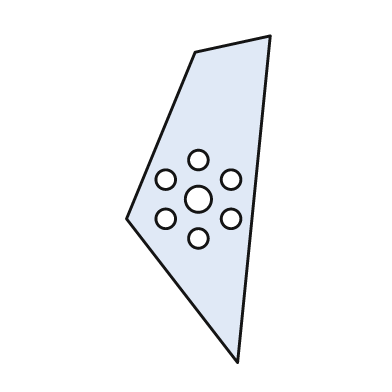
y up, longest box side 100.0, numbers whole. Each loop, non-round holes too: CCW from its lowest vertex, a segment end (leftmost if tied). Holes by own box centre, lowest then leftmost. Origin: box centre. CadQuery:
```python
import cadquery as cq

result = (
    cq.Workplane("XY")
    .moveTo(12.0, -50.0)
    .lineTo(22.0, 50.0)
    .lineTo(-1.0, 45.0)
    .lineTo(-22.0, -6.0)
    .close()
    .moveTo(0.0, -12.0)
    .circle(3.0)
    .moveTo(-10.0, -6.0)
    .circle(3.0)
    .moveTo(10.0, -6.0)
    .circle(3.0)
    .moveTo(0.0, 0.0)
    .circle(4.0)
    .moveTo(-10.0, 6.0)
    .circle(3.0)
    .moveTo(10.0, 6.0)
    .circle(3.0)
    .moveTo(0.0, 12.0)
    .circle(3.0)
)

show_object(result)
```